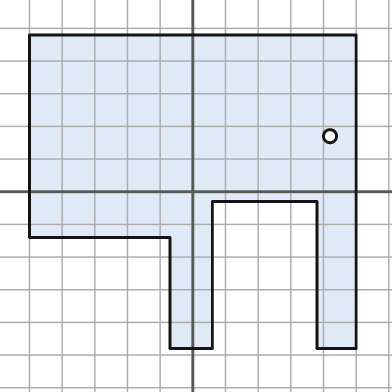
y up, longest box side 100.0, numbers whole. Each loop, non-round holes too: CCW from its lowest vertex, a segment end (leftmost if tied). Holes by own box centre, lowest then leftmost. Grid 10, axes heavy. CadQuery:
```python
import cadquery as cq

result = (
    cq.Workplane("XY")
    .moveTo(-7.0, -48.0)
    .lineTo(6.0, -48.0)
    .lineTo(6.0, -3.0)
    .lineTo(38.0, -3.0)
    .lineTo(38.0, -48.0)
    .lineTo(50.0, -48.0)
    .lineTo(50.0, 48.0)
    .lineTo(-50.0, 48.0)
    .lineTo(-50.0, -14.0)
    .lineTo(-7.0, -14.0)
    .close()
    .moveTo(42.0, 17.0)
    .circle(2.0)
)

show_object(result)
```